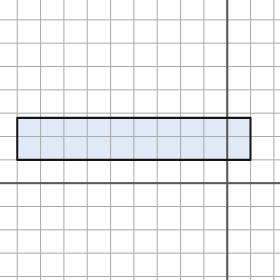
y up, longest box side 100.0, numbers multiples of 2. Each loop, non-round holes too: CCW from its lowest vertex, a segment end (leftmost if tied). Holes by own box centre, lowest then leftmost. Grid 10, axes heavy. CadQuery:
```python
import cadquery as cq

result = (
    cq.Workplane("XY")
    .moveTo(-90.0, 10.0)
    .lineTo(10.0, 10.0)
    .lineTo(10.0, 28.0)
    .lineTo(-90.0, 28.0)
    .close()
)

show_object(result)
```